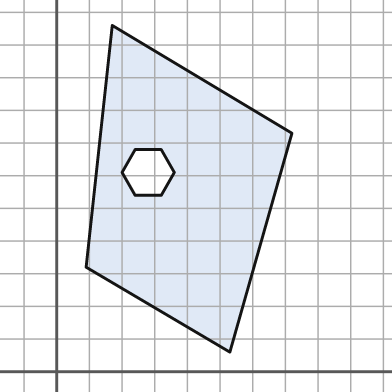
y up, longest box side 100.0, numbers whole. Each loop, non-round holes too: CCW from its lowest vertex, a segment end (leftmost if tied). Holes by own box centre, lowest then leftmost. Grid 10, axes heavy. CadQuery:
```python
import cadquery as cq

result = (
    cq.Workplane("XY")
    .moveTo(53.0, 6.0)
    .lineTo(72.0, 73.0)
    .lineTo(17.0, 106.0)
    .lineTo(9.0, 32.0)
    .close()
    .moveTo(24.0, 54.0)
    .lineTo(32.0, 54.0)
    .lineTo(36.0, 61.0)
    .lineTo(32.0, 68.0)
    .lineTo(24.0, 68.0)
    .lineTo(20.0, 61.0)
    .close()
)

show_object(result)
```